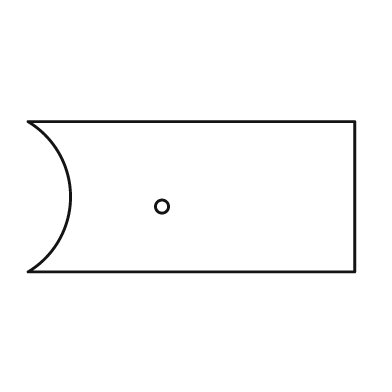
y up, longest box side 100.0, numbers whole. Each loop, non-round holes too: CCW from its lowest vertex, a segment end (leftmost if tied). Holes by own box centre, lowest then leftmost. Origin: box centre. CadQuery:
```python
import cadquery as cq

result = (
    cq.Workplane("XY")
    .moveTo(-50.0, -23.0)
    .lineTo(50.0, -23.0)
    .lineTo(50.0, 23.0)
    .lineTo(-50.0, 23.0)
    .threePointArc((-37.0, 0.0), (-50.0, -23.0))
    .close()
    .moveTo(-9.0, -3.0)
    .circle(2.0)
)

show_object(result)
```